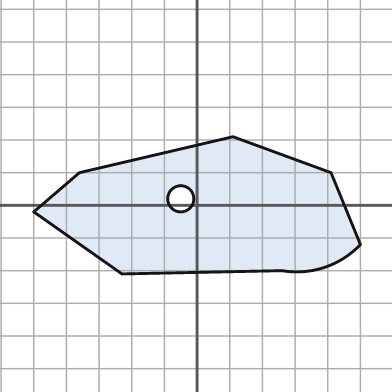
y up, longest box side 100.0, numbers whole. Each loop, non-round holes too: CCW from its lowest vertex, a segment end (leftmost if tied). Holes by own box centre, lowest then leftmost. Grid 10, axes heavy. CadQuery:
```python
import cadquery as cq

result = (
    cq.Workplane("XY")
    .moveTo(-23.0, -21.0)
    .lineTo(26.0, -20.0)
    .threePointArc((39.0, -19.0), (50.0, -12.0))
    .lineTo(41.0, 10.0)
    .lineTo(11.0, 21.0)
    .lineTo(-36.0, 10.0)
    .lineTo(-50.0, -2.0)
    .close()
    .moveTo(-5.0, 2.0)
    .circle(4.0)
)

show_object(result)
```